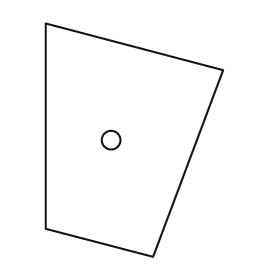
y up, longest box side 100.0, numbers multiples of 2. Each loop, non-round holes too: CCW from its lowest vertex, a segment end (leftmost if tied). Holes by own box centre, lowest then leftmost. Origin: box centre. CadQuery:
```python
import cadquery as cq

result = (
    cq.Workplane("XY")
    .moveTo(8.0, -50.0)
    .lineTo(38.0, 30.0)
    .lineTo(-38.0, 50.0)
    .lineTo(-38.0, -38.0)
    .close()
    .moveTo(-10.0, 0.0)
    .circle(4.0)
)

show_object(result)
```